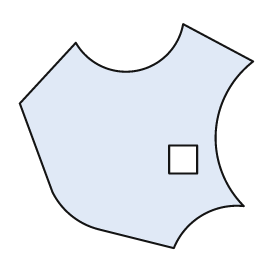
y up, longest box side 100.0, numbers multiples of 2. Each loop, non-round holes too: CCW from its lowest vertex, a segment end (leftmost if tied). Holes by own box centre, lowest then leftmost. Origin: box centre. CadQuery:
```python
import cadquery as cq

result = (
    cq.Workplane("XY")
    .moveTo(16.0, -48.0)
    .threePointArc((28.0, -34.0), (46.0, -30.0))
    .threePointArc((34.0, 2.0), (50.0, 32.0))
    .lineTo(20.0, 48.0)
    .threePointArc((0.0, 28.0), (-26.0, 40.0))
    .lineTo(-50.0, 14.0)
    .lineTo(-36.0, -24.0)
    .threePointArc((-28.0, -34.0), (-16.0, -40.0))
    .close()
    .moveTo(14.0, -16.0)
    .lineTo(26.0, -16.0)
    .lineTo(26.0, -4.0)
    .lineTo(14.0, -4.0)
    .close()
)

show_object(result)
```